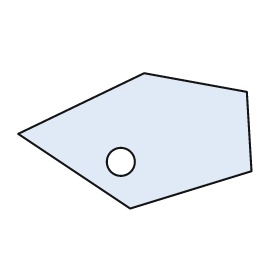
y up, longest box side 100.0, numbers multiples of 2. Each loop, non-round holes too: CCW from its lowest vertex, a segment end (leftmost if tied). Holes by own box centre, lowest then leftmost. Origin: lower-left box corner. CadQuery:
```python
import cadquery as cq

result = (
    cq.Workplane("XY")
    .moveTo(48.0, 0.0)
    .lineTo(100.0, 16.0)
    .lineTo(98.0, 50.0)
    .lineTo(54.0, 58.0)
    .lineTo(0.0, 32.0)
    .close()
    .moveTo(44.0, 20.0)
    .circle(6.0)
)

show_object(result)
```